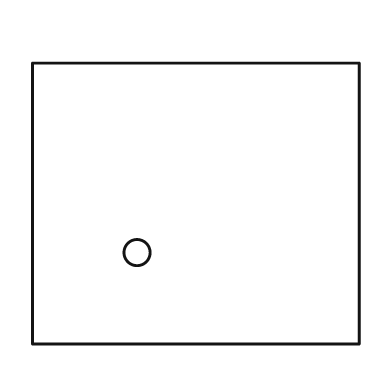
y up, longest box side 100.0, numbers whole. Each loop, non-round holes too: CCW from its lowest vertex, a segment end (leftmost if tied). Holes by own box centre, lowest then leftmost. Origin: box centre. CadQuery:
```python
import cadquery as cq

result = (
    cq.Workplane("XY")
    .moveTo(-50.0, -43.0)
    .lineTo(50.0, -43.0)
    .lineTo(50.0, 43.0)
    .lineTo(-50.0, 43.0)
    .close()
    .moveTo(-18.0, -15.0)
    .circle(4.0)
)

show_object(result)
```